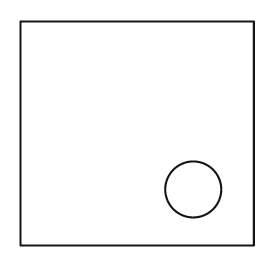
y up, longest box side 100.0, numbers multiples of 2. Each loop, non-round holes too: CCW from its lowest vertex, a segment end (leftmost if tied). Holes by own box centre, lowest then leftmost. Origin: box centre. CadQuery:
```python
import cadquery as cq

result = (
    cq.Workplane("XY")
    .moveTo(-50.0, -48.0)
    .lineTo(50.0, -48.0)
    .lineTo(50.0, 48.0)
    .lineTo(-50.0, 48.0)
    .close()
    .moveTo(24.0, -24.0)
    .circle(12.0)
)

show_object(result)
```